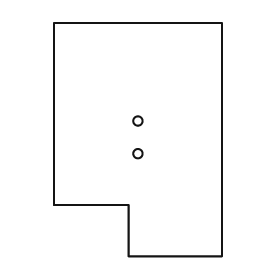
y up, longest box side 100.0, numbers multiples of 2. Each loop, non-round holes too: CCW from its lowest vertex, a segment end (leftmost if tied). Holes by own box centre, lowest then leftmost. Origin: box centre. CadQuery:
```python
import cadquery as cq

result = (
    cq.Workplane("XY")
    .moveTo(-4.0, -50.0)
    .lineTo(36.0, -50.0)
    .lineTo(36.0, 50.0)
    .lineTo(-36.0, 50.0)
    .lineTo(-36.0, -28.0)
    .lineTo(-4.0, -28.0)
    .close()
    .moveTo(0.0, -6.0)
    .circle(2.0)
    .moveTo(0.0, 8.0)
    .circle(2.0)
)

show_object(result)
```